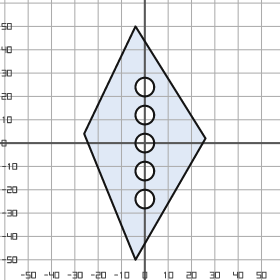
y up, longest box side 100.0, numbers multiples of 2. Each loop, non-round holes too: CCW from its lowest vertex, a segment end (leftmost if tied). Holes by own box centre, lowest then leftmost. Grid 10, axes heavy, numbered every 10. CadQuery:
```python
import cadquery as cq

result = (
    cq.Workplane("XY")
    .moveTo(-4.0, -50.0)
    .lineTo(26.0, 2.0)
    .lineTo(-4.0, 50.0)
    .lineTo(-26.0, 4.0)
    .close()
    .moveTo(0.0, -24.0)
    .circle(4.0)
    .moveTo(0.0, -12.0)
    .circle(4.0)
    .moveTo(0.0, 0.0)
    .circle(4.0)
    .moveTo(0.0, 12.0)
    .circle(4.0)
    .moveTo(0.0, 24.0)
    .circle(4.0)
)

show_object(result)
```